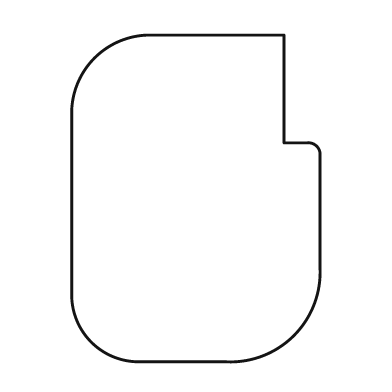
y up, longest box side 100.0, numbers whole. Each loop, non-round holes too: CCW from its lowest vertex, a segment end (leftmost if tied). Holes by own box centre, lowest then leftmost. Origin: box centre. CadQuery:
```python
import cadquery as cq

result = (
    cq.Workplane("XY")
    .moveTo(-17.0, -50.0)
    .lineTo(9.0, -50.0)
    .threePointArc((30.0, -42.0), (38.0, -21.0))
    .lineTo(38.0, 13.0)
    .threePointArc((37.0, 16.0), (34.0, 17.0))
    .lineTo(27.0, 17.0)
    .lineTo(27.0, 50.0)
    .lineTo(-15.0, 50.0)
    .threePointArc((-31.0, 43.0), (-38.0, 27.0))
    .lineTo(-38.0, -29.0)
    .threePointArc((-32.0, -44.0), (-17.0, -50.0))
    .close()
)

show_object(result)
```